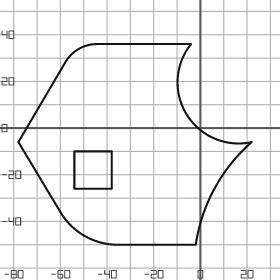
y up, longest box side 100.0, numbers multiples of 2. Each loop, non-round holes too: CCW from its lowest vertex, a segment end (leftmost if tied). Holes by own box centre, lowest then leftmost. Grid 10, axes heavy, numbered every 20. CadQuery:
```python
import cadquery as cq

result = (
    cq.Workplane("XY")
    .moveTo(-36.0, -50.0)
    .lineTo(-2.0, -50.0)
    .threePointArc((6.0, -26.0), (22.0, -6.0))
    .threePointArc((-6.0, 6.0), (-4.0, 36.0))
    .lineTo(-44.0, 36.0)
    .threePointArc((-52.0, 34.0), (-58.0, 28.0))
    .lineTo(-78.0, -6.0)
    .lineTo(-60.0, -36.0)
    .threePointArc((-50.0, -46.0), (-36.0, -50.0))
    .close()
    .moveTo(-54.0, -26.0)
    .lineTo(-38.0, -26.0)
    .lineTo(-38.0, -10.0)
    .lineTo(-54.0, -10.0)
    .close()
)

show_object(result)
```